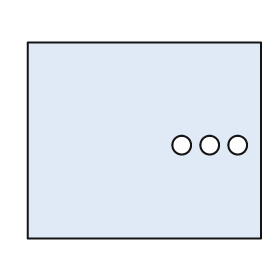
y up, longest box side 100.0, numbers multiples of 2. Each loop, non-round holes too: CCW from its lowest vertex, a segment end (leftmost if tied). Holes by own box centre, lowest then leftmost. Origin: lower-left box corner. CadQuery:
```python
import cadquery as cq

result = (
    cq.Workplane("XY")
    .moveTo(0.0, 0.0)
    .lineTo(100.0, 0.0)
    .lineTo(100.0, 84.0)
    .lineTo(0.0, 84.0)
    .close()
    .moveTo(66.0, 40.0)
    .circle(4.0)
    .moveTo(78.0, 40.0)
    .circle(4.0)
    .moveTo(90.0, 40.0)
    .circle(4.0)
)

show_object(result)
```